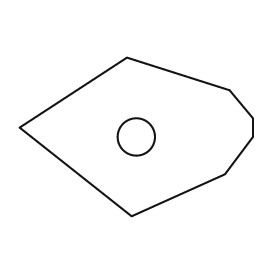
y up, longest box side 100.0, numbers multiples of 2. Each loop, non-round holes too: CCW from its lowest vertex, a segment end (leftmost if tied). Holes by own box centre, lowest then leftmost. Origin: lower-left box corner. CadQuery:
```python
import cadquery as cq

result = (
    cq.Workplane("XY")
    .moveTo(48.0, 0.0)
    .lineTo(88.0, 18.0)
    .lineTo(100.0, 34.0)
    .lineTo(100.0, 42.0)
    .lineTo(90.0, 54.0)
    .lineTo(46.0, 68.0)
    .lineTo(0.0, 38.0)
    .close()
    .moveTo(50.0, 34.0)
    .circle(8.0)
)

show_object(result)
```